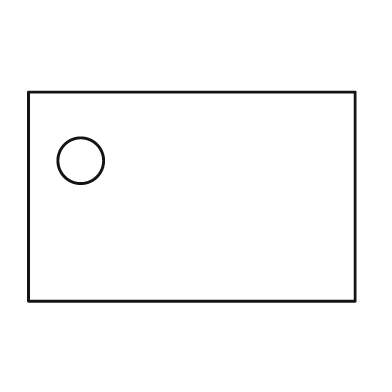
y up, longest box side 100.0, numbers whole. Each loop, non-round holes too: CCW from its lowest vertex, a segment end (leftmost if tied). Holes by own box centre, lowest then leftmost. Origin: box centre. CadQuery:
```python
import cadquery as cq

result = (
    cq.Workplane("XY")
    .moveTo(-50.0, -32.0)
    .lineTo(50.0, -32.0)
    .lineTo(50.0, 32.0)
    .lineTo(-50.0, 32.0)
    .close()
    .moveTo(-34.0, 11.0)
    .circle(7.0)
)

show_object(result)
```